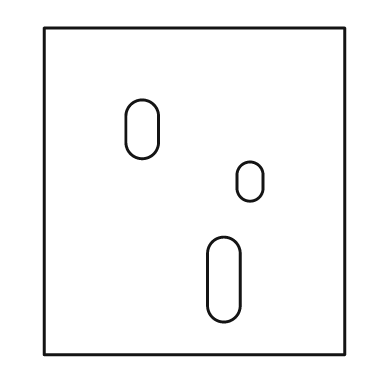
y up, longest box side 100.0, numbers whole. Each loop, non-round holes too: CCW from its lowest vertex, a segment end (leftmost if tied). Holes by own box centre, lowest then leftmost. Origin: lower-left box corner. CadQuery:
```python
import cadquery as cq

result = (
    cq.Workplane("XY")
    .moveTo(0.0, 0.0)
    .lineTo(92.0, 0.0)
    .lineTo(92.0, 100.0)
    .lineTo(0.0, 100.0)
    .close()
    .moveTo(50.0, 15.0)
    .threePointArc((55.0, 10.0), (60.0, 15.0))
    .lineTo(60.0, 31.0)
    .threePointArc((55.0, 36.0), (50.0, 31.0))
    .close()
    .moveTo(59.0, 51.0)
    .threePointArc((63.0, 47.0), (67.0, 51.0))
    .lineTo(67.0, 55.0)
    .threePointArc((63.0, 59.0), (59.0, 55.0))
    .close()
    .moveTo(25.0, 65.0)
    .threePointArc((30.0, 60.0), (35.0, 65.0))
    .lineTo(35.0, 73.0)
    .threePointArc((30.0, 78.0), (25.0, 73.0))
    .close()
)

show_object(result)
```